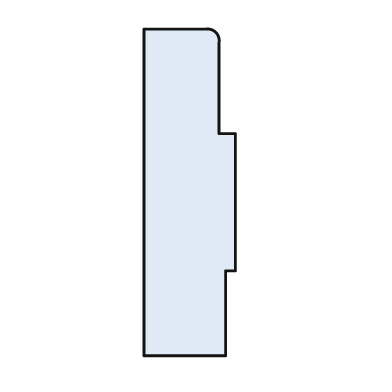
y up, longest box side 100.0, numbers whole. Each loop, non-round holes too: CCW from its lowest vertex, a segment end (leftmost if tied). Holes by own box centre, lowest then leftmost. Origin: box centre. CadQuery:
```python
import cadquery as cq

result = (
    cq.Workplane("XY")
    .moveTo(-14.0, -50.0)
    .lineTo(11.0, -50.0)
    .lineTo(11.0, -24.0)
    .lineTo(14.0, -24.0)
    .lineTo(14.0, 18.0)
    .lineTo(9.0, 18.0)
    .lineTo(9.0, 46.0)
    .threePointArc((8.0, 49.0), (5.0, 50.0))
    .lineTo(-14.0, 50.0)
    .close()
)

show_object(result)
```